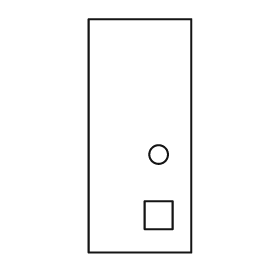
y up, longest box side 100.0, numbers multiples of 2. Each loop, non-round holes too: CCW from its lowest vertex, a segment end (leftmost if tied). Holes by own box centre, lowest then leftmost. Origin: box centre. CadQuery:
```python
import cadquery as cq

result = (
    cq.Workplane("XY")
    .moveTo(-22.0, -50.0)
    .lineTo(22.0, -50.0)
    .lineTo(22.0, 50.0)
    .lineTo(-22.0, 50.0)
    .close()
    .moveTo(2.0, -40.0)
    .lineTo(14.0, -40.0)
    .lineTo(14.0, -28.0)
    .lineTo(2.0, -28.0)
    .close()
    .moveTo(8.0, -8.0)
    .circle(4.0)
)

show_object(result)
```